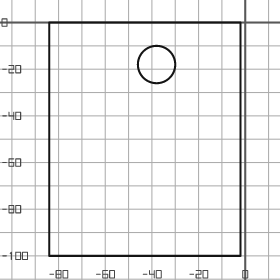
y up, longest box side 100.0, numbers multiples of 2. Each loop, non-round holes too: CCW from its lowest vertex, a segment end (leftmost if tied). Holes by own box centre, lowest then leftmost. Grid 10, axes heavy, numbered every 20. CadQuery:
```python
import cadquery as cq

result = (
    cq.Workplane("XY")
    .moveTo(-84.0, -100.0)
    .lineTo(-2.0, -100.0)
    .lineTo(-2.0, 0.0)
    .lineTo(-84.0, 0.0)
    .close()
    .moveTo(-38.0, -18.0)
    .circle(8.0)
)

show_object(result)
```